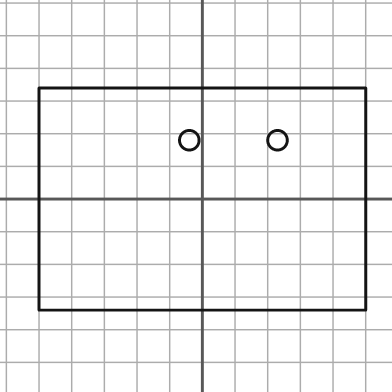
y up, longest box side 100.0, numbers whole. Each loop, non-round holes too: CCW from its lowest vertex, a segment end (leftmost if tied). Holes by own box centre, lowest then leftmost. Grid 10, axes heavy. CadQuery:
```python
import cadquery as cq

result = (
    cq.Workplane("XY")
    .moveTo(-50.0, -34.0)
    .lineTo(50.0, -34.0)
    .lineTo(50.0, 34.0)
    .lineTo(-50.0, 34.0)
    .close()
    .moveTo(-4.0, 18.0)
    .circle(3.0)
    .moveTo(23.0, 18.0)
    .circle(3.0)
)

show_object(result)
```